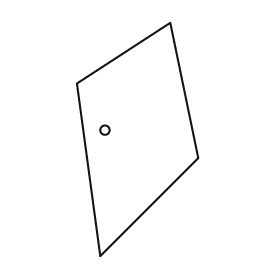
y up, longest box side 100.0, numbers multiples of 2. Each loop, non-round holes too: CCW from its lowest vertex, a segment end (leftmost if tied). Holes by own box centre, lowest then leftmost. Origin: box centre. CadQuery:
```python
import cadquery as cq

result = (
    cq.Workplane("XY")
    .moveTo(-16.0, -50.0)
    .lineTo(26.0, -8.0)
    .lineTo(14.0, 50.0)
    .lineTo(-26.0, 24.0)
    .close()
    .moveTo(-14.0, 4.0)
    .circle(2.0)
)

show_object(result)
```